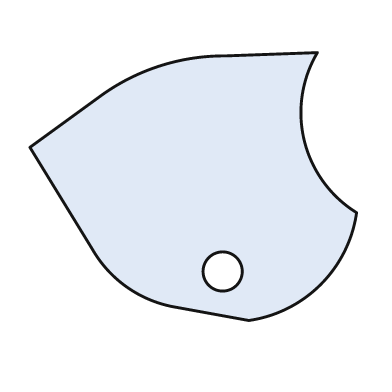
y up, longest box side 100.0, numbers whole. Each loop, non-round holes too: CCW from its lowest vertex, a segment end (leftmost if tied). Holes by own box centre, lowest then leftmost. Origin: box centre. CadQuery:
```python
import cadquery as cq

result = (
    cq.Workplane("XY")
    .moveTo(17.0, -41.0)
    .threePointArc((39.0, -30.0), (50.0, -8.0))
    .threePointArc((34.0, 14.0), (38.0, 41.0))
    .lineTo(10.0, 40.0)
    .threePointArc((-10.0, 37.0), (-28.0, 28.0))
    .lineTo(-50.0, 12.0)
    .lineTo(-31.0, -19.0)
    .threePointArc((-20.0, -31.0), (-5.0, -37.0))
    .close()
    .moveTo(9.0, -26.0)
    .circle(6.0)
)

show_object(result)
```